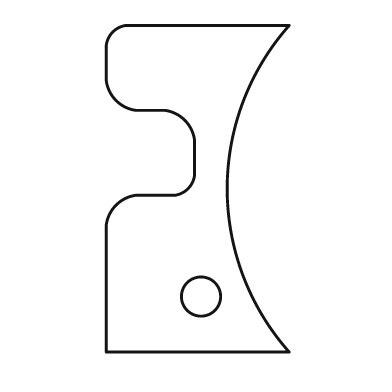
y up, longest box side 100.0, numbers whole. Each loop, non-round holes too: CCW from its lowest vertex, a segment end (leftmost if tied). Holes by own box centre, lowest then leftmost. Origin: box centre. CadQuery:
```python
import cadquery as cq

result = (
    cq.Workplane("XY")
    .moveTo(-28.0, -50.0)
    .lineTo(28.0, -50.0)
    .threePointArc((9.0, 0.0), (28.0, 50.0))
    .lineTo(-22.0, 50.0)
    .threePointArc((-26.0, 48.0), (-28.0, 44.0))
    .lineTo(-28.0, 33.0)
    .threePointArc((-25.0, 27.0), (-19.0, 24.0))
    .lineTo(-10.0, 24.0)
    .threePointArc((-4.0, 21.0), (-1.0, 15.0))
    .lineTo(-1.0, 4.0)
    .threePointArc((-3.0, 0.0), (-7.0, -2.0))
    .lineTo(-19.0, -2.0)
    .threePointArc((-25.0, -5.0), (-28.0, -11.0))
    .close()
    .moveTo(1.0, -33.0)
    .circle(6.0)
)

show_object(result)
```